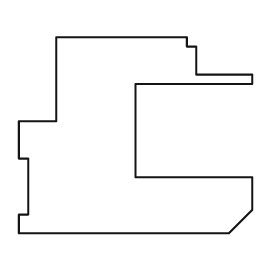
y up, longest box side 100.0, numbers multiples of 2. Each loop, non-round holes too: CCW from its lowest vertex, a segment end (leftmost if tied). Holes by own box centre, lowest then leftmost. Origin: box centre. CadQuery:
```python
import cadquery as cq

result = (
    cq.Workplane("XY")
    .moveTo(-50.0, -42.0)
    .lineTo(40.0, -42.0)
    .lineTo(50.0, -32.0)
    .lineTo(50.0, -18.0)
    .lineTo(0.0, -18.0)
    .lineTo(0.0, 22.0)
    .lineTo(50.0, 22.0)
    .lineTo(50.0, 26.0)
    .lineTo(26.0, 26.0)
    .lineTo(26.0, 38.0)
    .lineTo(22.0, 38.0)
    .lineTo(22.0, 42.0)
    .lineTo(-34.0, 42.0)
    .lineTo(-34.0, 6.0)
    .lineTo(-50.0, 6.0)
    .lineTo(-50.0, -10.0)
    .lineTo(-46.0, -10.0)
    .lineTo(-46.0, -34.0)
    .lineTo(-50.0, -34.0)
    .close()
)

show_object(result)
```